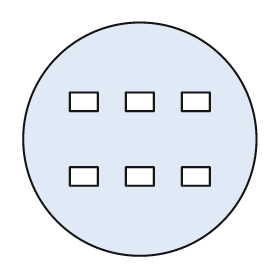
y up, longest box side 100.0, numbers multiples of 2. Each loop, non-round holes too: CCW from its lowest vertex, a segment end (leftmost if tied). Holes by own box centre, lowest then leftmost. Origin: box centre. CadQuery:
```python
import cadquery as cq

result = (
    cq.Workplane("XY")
    .moveTo(0.0, 0.0)
    .circle(50.0)
    .moveTo(-30.0, -20.0)
    .lineTo(-18.0, -20.0)
    .lineTo(-18.0, -12.0)
    .lineTo(-30.0, -12.0)
    .close()
    .moveTo(-6.0, -20.0)
    .lineTo(6.0, -20.0)
    .lineTo(6.0, -12.0)
    .lineTo(-6.0, -12.0)
    .close()
    .moveTo(18.0, -20.0)
    .lineTo(30.0, -20.0)
    .lineTo(30.0, -12.0)
    .lineTo(18.0, -12.0)
    .close()
    .moveTo(-30.0, 12.0)
    .lineTo(-18.0, 12.0)
    .lineTo(-18.0, 20.0)
    .lineTo(-30.0, 20.0)
    .close()
    .moveTo(-6.0, 12.0)
    .lineTo(6.0, 12.0)
    .lineTo(6.0, 20.0)
    .lineTo(-6.0, 20.0)
    .close()
    .moveTo(18.0, 12.0)
    .lineTo(30.0, 12.0)
    .lineTo(30.0, 20.0)
    .lineTo(18.0, 20.0)
    .close()
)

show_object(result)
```